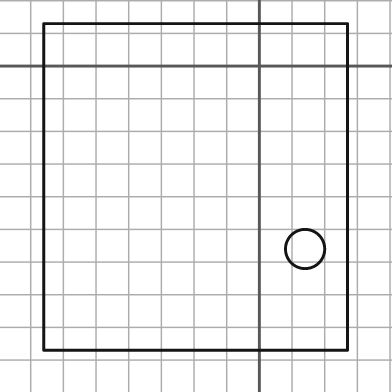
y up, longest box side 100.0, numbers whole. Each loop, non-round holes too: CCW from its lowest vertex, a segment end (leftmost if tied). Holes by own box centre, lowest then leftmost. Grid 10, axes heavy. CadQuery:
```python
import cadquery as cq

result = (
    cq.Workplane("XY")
    .moveTo(-66.0, -87.0)
    .lineTo(27.0, -87.0)
    .lineTo(27.0, 13.0)
    .lineTo(-66.0, 13.0)
    .close()
    .moveTo(14.0, -56.0)
    .circle(6.0)
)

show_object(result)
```